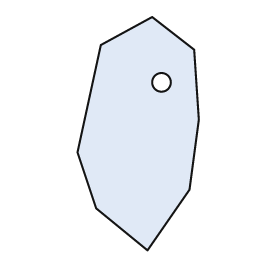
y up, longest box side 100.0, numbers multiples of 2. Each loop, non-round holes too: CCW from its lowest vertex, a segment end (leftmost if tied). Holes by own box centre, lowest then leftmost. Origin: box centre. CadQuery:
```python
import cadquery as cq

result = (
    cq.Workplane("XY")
    .moveTo(4.0, -50.0)
    .lineTo(22.0, -24.0)
    .lineTo(26.0, 6.0)
    .lineTo(24.0, 36.0)
    .lineTo(6.0, 50.0)
    .lineTo(-16.0, 38.0)
    .lineTo(-26.0, -8.0)
    .lineTo(-18.0, -32.0)
    .close()
    .moveTo(10.0, 22.0)
    .circle(4.0)
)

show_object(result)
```